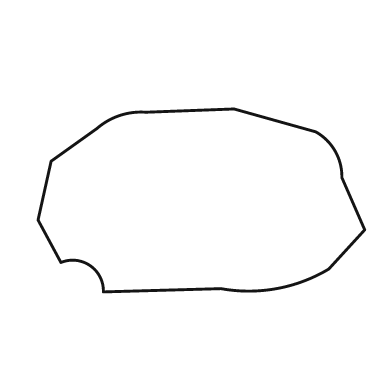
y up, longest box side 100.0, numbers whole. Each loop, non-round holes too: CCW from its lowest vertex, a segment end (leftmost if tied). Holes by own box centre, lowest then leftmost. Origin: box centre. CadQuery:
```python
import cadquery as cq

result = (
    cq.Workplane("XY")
    .moveTo(-30.0, -28.0)
    .lineTo(6.0, -27.0)
    .threePointArc((23.0, -27.0), (39.0, -21.0))
    .lineTo(50.0, -9.0)
    .lineTo(43.0, 7.0)
    .threePointArc((41.0, 15.0), (35.0, 21.0))
    .lineTo(10.0, 28.0)
    .lineTo(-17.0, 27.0)
    .threePointArc((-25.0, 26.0), (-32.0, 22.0))
    .lineTo(-46.0, 12.0)
    .lineTo(-50.0, -6.0)
    .lineTo(-43.0, -19.0)
    .threePointArc((-34.0, -20.0), (-30.0, -28.0))
    .close()
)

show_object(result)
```